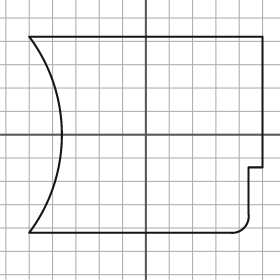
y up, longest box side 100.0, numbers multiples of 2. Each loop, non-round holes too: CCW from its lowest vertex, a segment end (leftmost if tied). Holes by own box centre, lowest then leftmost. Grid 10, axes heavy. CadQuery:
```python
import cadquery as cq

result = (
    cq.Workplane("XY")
    .moveTo(-50.0, -42.0)
    .lineTo(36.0, -42.0)
    .threePointArc((42.0, -40.0), (44.0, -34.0))
    .lineTo(44.0, -14.0)
    .lineTo(50.0, -14.0)
    .lineTo(50.0, 42.0)
    .lineTo(-50.0, 42.0)
    .threePointArc((-36.0, 0.0), (-50.0, -42.0))
    .close()
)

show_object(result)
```